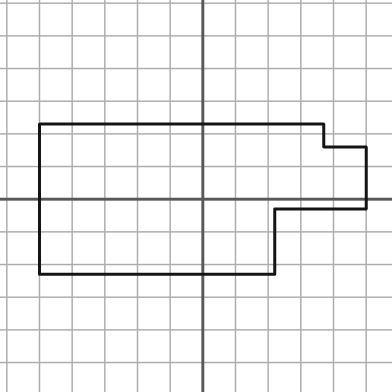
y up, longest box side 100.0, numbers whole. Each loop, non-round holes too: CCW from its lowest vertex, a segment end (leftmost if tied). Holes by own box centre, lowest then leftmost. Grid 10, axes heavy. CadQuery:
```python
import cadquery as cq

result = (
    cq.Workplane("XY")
    .moveTo(-50.0, -23.0)
    .lineTo(22.0, -23.0)
    .lineTo(22.0, -3.0)
    .lineTo(50.0, -3.0)
    .lineTo(50.0, 16.0)
    .lineTo(37.0, 16.0)
    .lineTo(37.0, 23.0)
    .lineTo(-50.0, 23.0)
    .close()
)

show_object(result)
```